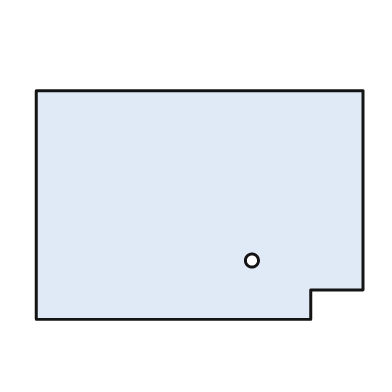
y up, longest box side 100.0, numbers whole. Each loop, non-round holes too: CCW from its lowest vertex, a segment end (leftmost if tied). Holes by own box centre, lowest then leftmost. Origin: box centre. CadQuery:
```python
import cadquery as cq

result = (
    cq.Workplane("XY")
    .moveTo(-50.0, -35.0)
    .lineTo(34.0, -35.0)
    .lineTo(34.0, -26.0)
    .lineTo(50.0, -26.0)
    .lineTo(50.0, 35.0)
    .lineTo(-50.0, 35.0)
    .close()
    .moveTo(16.0, -17.0)
    .circle(2.0)
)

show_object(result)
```